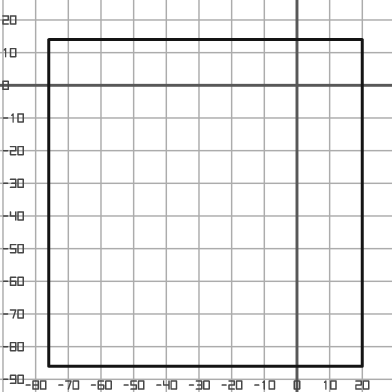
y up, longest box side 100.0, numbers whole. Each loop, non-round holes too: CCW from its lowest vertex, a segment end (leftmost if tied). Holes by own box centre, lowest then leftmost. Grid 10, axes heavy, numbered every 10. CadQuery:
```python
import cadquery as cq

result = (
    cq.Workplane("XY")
    .moveTo(-76.0, -86.0)
    .lineTo(20.0, -86.0)
    .lineTo(20.0, 14.0)
    .lineTo(-76.0, 14.0)
    .close()
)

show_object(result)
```